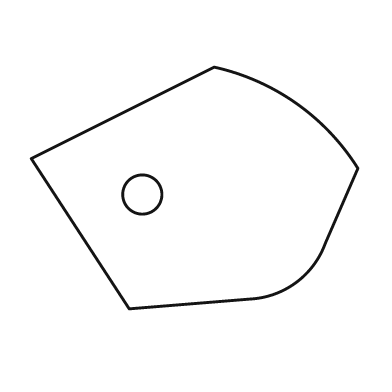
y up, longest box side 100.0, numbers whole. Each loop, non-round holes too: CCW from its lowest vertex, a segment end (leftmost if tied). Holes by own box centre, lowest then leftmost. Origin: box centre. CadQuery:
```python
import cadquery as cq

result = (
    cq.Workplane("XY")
    .moveTo(-20.0, -37.0)
    .lineTo(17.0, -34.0)
    .threePointArc((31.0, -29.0), (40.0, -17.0))
    .lineTo(50.0, 6.0)
    .threePointArc((31.0, 26.0), (6.0, 37.0))
    .lineTo(-50.0, 9.0)
    .close()
    .moveTo(-16.0, -2.0)
    .circle(6.0)
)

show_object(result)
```